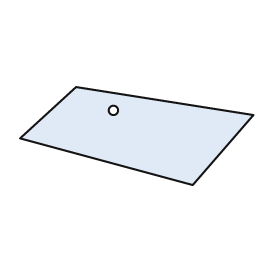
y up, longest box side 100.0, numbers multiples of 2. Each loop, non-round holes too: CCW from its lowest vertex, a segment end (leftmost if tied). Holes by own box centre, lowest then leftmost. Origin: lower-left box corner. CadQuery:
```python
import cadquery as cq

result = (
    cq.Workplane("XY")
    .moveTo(74.0, 0.0)
    .lineTo(100.0, 30.0)
    .lineTo(24.0, 42.0)
    .lineTo(0.0, 20.0)
    .close()
    .moveTo(40.0, 32.0)
    .circle(2.0)
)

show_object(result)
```